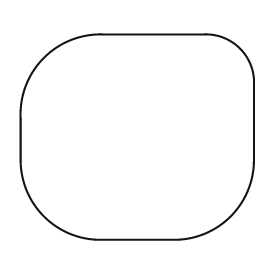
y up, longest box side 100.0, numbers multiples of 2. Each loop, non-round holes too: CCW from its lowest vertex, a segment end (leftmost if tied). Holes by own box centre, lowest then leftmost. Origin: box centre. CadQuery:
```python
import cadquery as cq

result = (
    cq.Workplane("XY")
    .moveTo(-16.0, -44.0)
    .lineTo(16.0, -44.0)
    .threePointArc((40.0, -34.0), (50.0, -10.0))
    .lineTo(50.0, 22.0)
    .threePointArc((44.0, 38.0), (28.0, 44.0))
    .lineTo(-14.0, 44.0)
    .threePointArc((-40.0, 34.0), (-50.0, 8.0))
    .lineTo(-50.0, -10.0)
    .threePointArc((-40.0, -34.0), (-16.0, -44.0))
    .close()
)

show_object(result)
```